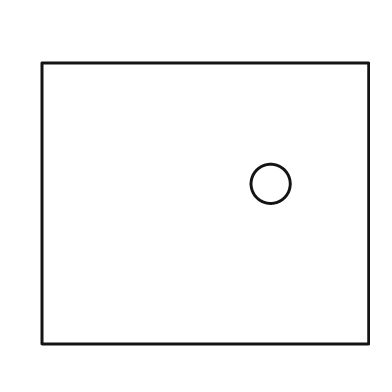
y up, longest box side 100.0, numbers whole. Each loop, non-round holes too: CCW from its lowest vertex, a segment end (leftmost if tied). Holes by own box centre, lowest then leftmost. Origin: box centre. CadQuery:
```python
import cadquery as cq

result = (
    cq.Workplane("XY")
    .moveTo(-50.0, -43.0)
    .lineTo(50.0, -43.0)
    .lineTo(50.0, 43.0)
    .lineTo(-50.0, 43.0)
    .close()
    .moveTo(20.0, 6.0)
    .circle(6.0)
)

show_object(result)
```